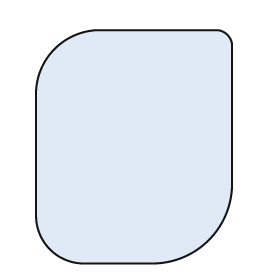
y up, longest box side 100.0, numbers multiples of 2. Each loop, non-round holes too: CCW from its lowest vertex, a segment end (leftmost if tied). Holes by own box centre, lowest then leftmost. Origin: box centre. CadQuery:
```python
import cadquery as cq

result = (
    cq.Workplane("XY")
    .moveTo(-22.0, -50.0)
    .lineTo(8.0, -50.0)
    .threePointArc((32.0, -40.0), (42.0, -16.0))
    .lineTo(42.0, 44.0)
    .threePointArc((40.0, 48.0), (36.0, 50.0))
    .lineTo(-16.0, 50.0)
    .threePointArc((-34.0, 42.0), (-42.0, 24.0))
    .lineTo(-42.0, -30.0)
    .threePointArc((-36.0, -44.0), (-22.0, -50.0))
    .close()
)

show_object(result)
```